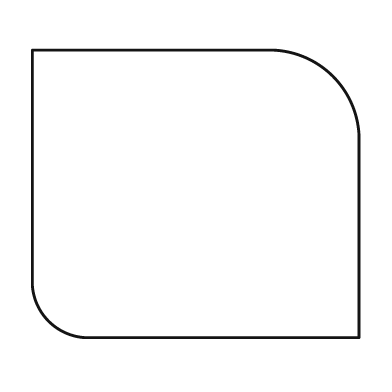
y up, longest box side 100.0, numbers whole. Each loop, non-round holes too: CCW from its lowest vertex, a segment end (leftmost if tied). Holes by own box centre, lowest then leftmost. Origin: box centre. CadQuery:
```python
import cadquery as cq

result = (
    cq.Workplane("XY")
    .moveTo(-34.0, -44.0)
    .lineTo(50.0, -44.0)
    .lineTo(50.0, 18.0)
    .threePointArc((42.0, 36.0), (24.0, 44.0))
    .lineTo(-50.0, 44.0)
    .lineTo(-50.0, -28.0)
    .threePointArc((-45.0, -39.0), (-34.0, -44.0))
    .close()
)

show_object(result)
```